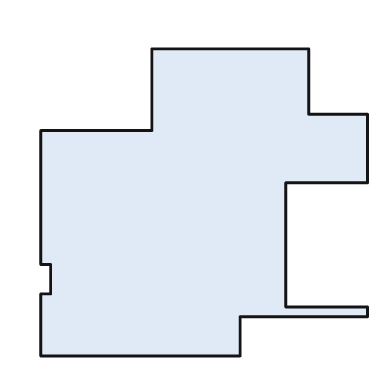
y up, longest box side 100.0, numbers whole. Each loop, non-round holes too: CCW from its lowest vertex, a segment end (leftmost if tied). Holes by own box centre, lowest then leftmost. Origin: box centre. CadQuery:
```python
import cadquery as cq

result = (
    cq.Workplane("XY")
    .moveTo(-50.0, -47.0)
    .lineTo(11.0, -47.0)
    .lineTo(11.0, -35.0)
    .lineTo(50.0, -35.0)
    .lineTo(50.0, -32.0)
    .lineTo(25.0, -32.0)
    .lineTo(25.0, 6.0)
    .lineTo(50.0, 6.0)
    .lineTo(50.0, 27.0)
    .lineTo(32.0, 27.0)
    .lineTo(32.0, 47.0)
    .lineTo(-16.0, 47.0)
    .lineTo(-16.0, 22.0)
    .lineTo(-50.0, 22.0)
    .lineTo(-50.0, -19.0)
    .lineTo(-47.0, -19.0)
    .lineTo(-47.0, -28.0)
    .lineTo(-50.0, -28.0)
    .close()
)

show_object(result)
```